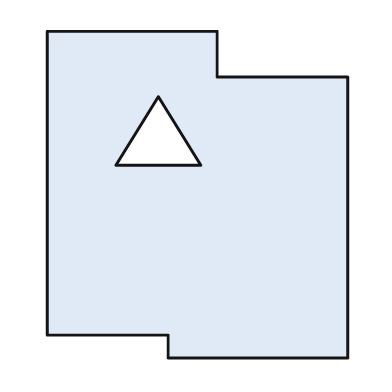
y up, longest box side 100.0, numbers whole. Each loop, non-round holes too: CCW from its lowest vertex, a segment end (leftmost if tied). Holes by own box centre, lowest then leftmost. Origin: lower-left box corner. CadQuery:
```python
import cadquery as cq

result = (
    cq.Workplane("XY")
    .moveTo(37.0, 0.0)
    .lineTo(92.0, 0.0)
    .lineTo(92.0, 86.0)
    .lineTo(52.0, 86.0)
    .lineTo(52.0, 100.0)
    .lineTo(0.0, 100.0)
    .lineTo(0.0, 7.0)
    .lineTo(37.0, 7.0)
    .close()
    .moveTo(21.0, 59.0)
    .lineTo(47.0, 59.0)
    .lineTo(34.0, 80.0)
    .close()
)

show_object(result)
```